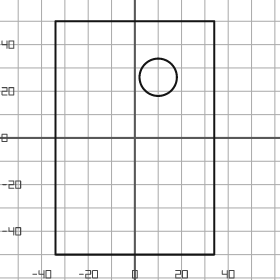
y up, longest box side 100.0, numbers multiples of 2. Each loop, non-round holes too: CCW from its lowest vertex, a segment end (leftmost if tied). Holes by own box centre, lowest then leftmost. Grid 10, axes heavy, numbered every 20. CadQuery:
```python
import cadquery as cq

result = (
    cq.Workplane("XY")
    .moveTo(-34.0, -50.0)
    .lineTo(34.0, -50.0)
    .lineTo(34.0, 50.0)
    .lineTo(-34.0, 50.0)
    .close()
    .moveTo(10.0, 26.0)
    .circle(8.0)
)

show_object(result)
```